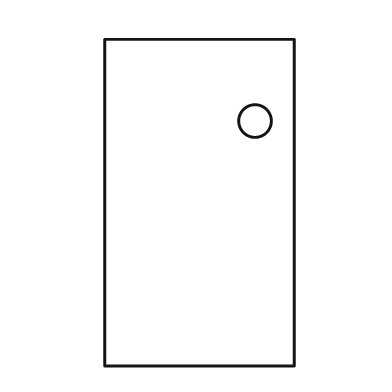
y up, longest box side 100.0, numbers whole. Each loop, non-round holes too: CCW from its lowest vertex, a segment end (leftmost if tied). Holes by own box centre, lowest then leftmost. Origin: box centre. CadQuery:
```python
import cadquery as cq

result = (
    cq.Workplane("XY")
    .moveTo(-29.0, -50.0)
    .lineTo(29.0, -50.0)
    .lineTo(29.0, 50.0)
    .lineTo(-29.0, 50.0)
    .close()
    .moveTo(17.0, 25.0)
    .circle(5.0)
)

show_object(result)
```